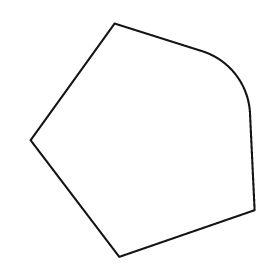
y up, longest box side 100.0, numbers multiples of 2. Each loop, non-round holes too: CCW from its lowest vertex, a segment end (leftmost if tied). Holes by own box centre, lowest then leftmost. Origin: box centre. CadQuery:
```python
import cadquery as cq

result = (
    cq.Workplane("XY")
    .moveTo(-10.0, -50.0)
    .lineTo(48.0, -30.0)
    .lineTo(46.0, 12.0)
    .threePointArc((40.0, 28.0), (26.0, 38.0))
    .lineTo(-12.0, 50.0)
    .lineTo(-48.0, 0.0)
    .close()
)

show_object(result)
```